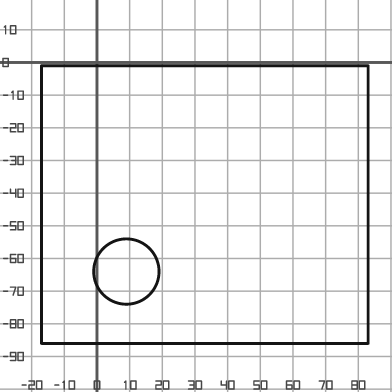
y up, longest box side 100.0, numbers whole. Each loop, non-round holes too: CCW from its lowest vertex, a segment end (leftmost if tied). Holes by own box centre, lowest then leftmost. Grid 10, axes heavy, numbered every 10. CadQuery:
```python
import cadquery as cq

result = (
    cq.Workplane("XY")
    .moveTo(-17.0, -86.0)
    .lineTo(83.0, -86.0)
    .lineTo(83.0, -1.0)
    .lineTo(-17.0, -1.0)
    .close()
    .moveTo(9.0, -64.0)
    .circle(10.0)
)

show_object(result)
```